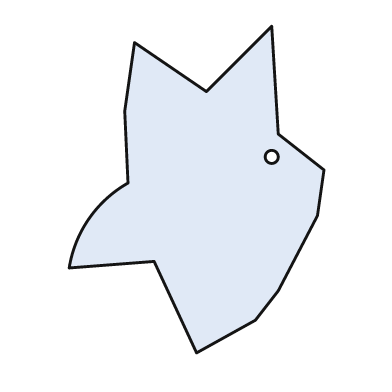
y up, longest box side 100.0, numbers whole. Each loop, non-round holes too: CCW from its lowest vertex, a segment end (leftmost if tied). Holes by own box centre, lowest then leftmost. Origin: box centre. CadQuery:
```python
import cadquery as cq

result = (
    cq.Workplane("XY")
    .moveTo(0.0, -50.0)
    .lineTo(18.0, -40.0)
    .lineTo(25.0, -31.0)
    .lineTo(37.0, -8.0)
    .lineTo(39.0, 6.0)
    .lineTo(25.0, 17.0)
    .lineTo(23.0, 50.0)
    .lineTo(3.0, 30.0)
    .lineTo(-19.0, 45.0)
    .lineTo(-22.0, 24.0)
    .lineTo(-21.0, 2.0)
    .threePointArc((-33.0, -9.0), (-39.0, -24.0))
    .lineTo(-13.0, -22.0)
    .close()
    .moveTo(23.0, 10.0)
    .circle(2.0)
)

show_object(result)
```